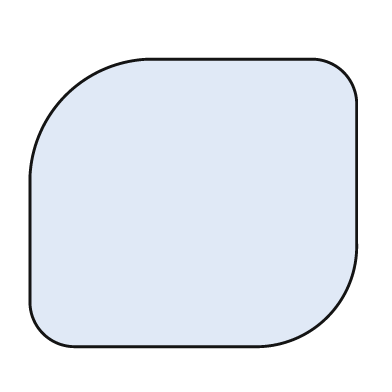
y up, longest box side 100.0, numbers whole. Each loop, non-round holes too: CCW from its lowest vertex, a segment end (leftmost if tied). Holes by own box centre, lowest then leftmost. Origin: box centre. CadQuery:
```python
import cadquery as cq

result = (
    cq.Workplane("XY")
    .moveTo(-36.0, -44.0)
    .lineTo(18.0, -44.0)
    .threePointArc((41.0, -35.0), (50.0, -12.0))
    .lineTo(50.0, 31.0)
    .threePointArc((46.0, 40.0), (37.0, 44.0))
    .lineTo(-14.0, 44.0)
    .threePointArc((-39.0, 33.0), (-50.0, 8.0))
    .lineTo(-50.0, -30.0)
    .threePointArc((-46.0, -40.0), (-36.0, -44.0))
    .close()
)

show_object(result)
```